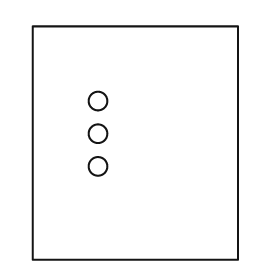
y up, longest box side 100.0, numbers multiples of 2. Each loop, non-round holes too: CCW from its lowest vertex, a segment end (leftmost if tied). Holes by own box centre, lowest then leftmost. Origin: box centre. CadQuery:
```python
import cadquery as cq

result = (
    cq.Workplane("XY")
    .moveTo(-44.0, -50.0)
    .lineTo(44.0, -50.0)
    .lineTo(44.0, 50.0)
    .lineTo(-44.0, 50.0)
    .close()
    .moveTo(-16.0, -10.0)
    .circle(4.0)
    .moveTo(-16.0, 4.0)
    .circle(4.0)
    .moveTo(-16.0, 18.0)
    .circle(4.0)
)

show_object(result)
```